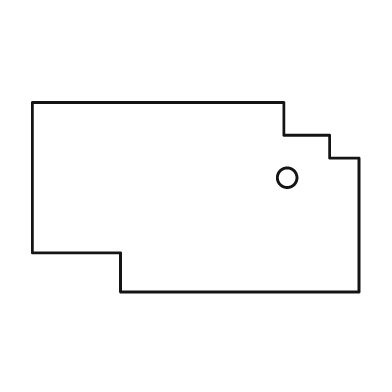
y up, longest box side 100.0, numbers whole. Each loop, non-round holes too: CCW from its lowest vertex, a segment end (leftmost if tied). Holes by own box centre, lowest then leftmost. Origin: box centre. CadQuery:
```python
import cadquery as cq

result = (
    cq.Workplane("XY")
    .moveTo(-23.0, -29.0)
    .lineTo(50.0, -29.0)
    .lineTo(50.0, 12.0)
    .lineTo(41.0, 12.0)
    .lineTo(41.0, 19.0)
    .lineTo(27.0, 19.0)
    .lineTo(27.0, 29.0)
    .lineTo(-50.0, 29.0)
    .lineTo(-50.0, -17.0)
    .lineTo(-23.0, -17.0)
    .close()
    .moveTo(28.0, 6.0)
    .circle(3.0)
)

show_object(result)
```